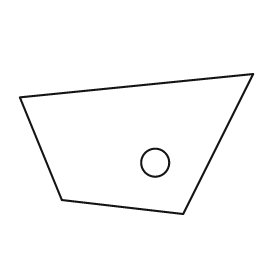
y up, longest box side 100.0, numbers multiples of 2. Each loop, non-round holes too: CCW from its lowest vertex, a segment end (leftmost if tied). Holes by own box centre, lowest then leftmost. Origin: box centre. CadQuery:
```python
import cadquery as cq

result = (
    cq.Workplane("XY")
    .moveTo(20.0, -30.0)
    .lineTo(50.0, 30.0)
    .lineTo(-50.0, 20.0)
    .lineTo(-32.0, -24.0)
    .close()
    .moveTo(8.0, -8.0)
    .circle(6.0)
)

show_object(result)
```